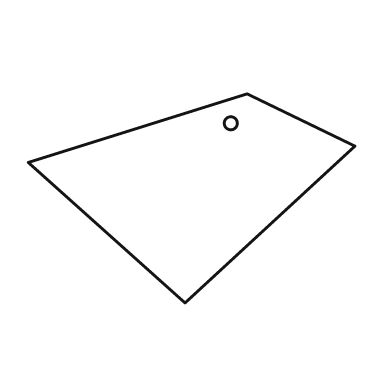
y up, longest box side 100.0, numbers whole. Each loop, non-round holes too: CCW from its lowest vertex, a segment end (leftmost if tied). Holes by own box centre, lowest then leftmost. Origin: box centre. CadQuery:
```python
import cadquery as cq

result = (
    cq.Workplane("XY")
    .moveTo(-2.0, -32.0)
    .lineTo(50.0, 16.0)
    .lineTo(17.0, 32.0)
    .lineTo(-50.0, 11.0)
    .close()
    .moveTo(12.0, 23.0)
    .circle(2.0)
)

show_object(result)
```